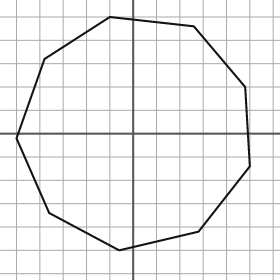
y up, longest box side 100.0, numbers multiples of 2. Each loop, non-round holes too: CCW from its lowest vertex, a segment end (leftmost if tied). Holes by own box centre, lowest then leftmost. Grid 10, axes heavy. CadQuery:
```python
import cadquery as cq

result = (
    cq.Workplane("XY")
    .moveTo(-6.0, -50.0)
    .lineTo(28.0, -42.0)
    .lineTo(50.0, -14.0)
    .lineTo(48.0, 20.0)
    .lineTo(26.0, 46.0)
    .lineTo(-10.0, 50.0)
    .lineTo(-38.0, 32.0)
    .lineTo(-50.0, -2.0)
    .lineTo(-36.0, -34.0)
    .close()
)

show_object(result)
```